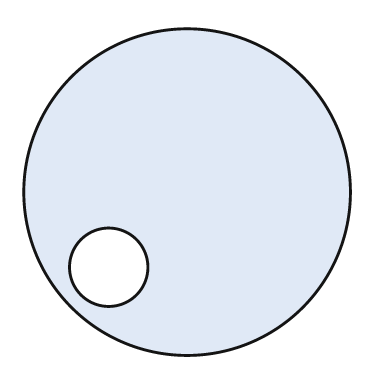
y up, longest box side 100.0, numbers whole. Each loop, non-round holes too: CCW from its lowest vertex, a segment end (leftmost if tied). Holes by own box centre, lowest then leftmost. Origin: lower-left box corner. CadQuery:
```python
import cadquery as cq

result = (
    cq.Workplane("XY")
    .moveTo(50.0, 50.0)
    .circle(50.0)
    .moveTo(26.0, 27.0)
    .circle(12.0)
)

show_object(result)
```